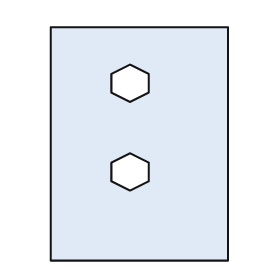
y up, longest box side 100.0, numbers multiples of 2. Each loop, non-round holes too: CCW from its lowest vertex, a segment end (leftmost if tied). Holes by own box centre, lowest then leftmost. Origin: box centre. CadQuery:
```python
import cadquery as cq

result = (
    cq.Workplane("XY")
    .moveTo(-38.0, -50.0)
    .lineTo(38.0, -50.0)
    .lineTo(38.0, 50.0)
    .lineTo(-38.0, 50.0)
    .close()
    .moveTo(-4.0, -20.0)
    .lineTo(4.0, -16.0)
    .lineTo(4.0, -8.0)
    .lineTo(-4.0, -4.0)
    .lineTo(-12.0, -8.0)
    .lineTo(-12.0, -16.0)
    .close()
    .moveTo(-4.0, 18.0)
    .lineTo(4.0, 22.0)
    .lineTo(4.0, 30.0)
    .lineTo(-4.0, 34.0)
    .lineTo(-12.0, 30.0)
    .lineTo(-12.0, 22.0)
    .close()
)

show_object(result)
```